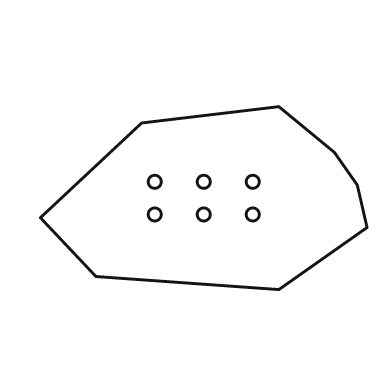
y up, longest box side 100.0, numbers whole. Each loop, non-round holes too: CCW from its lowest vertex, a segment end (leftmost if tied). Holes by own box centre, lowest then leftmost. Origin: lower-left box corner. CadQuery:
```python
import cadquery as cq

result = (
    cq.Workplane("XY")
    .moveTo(73.0, 0.0)
    .lineTo(100.0, 19.0)
    .lineTo(97.0, 32.0)
    .lineTo(90.0, 42.0)
    .lineTo(73.0, 56.0)
    .lineTo(31.0, 51.0)
    .lineTo(0.0, 22.0)
    .lineTo(17.0, 4.0)
    .close()
    .moveTo(35.0, 23.0)
    .circle(2.0)
    .moveTo(50.0, 23.0)
    .circle(2.0)
    .moveTo(65.0, 23.0)
    .circle(2.0)
    .moveTo(35.0, 33.0)
    .circle(2.0)
    .moveTo(50.0, 33.0)
    .circle(2.0)
    .moveTo(65.0, 33.0)
    .circle(2.0)
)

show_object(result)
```